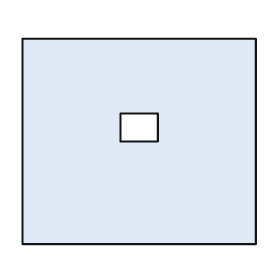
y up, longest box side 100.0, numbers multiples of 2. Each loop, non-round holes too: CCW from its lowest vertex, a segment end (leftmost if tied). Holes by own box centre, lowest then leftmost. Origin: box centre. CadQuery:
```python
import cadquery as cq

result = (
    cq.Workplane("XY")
    .moveTo(-50.0, -44.0)
    .lineTo(50.0, -44.0)
    .lineTo(50.0, 44.0)
    .lineTo(-50.0, 44.0)
    .close()
    .moveTo(-8.0, 0.0)
    .lineTo(8.0, 0.0)
    .lineTo(8.0, 12.0)
    .lineTo(-8.0, 12.0)
    .close()
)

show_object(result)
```